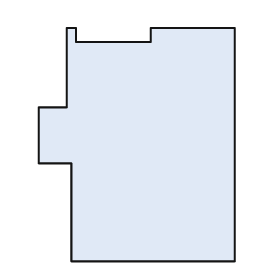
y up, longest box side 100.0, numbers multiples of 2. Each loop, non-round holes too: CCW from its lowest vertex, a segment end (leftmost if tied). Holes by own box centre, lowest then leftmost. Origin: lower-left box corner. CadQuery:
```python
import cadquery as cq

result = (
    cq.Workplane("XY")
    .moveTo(14.0, 0.0)
    .lineTo(84.0, 0.0)
    .lineTo(84.0, 100.0)
    .lineTo(48.0, 100.0)
    .lineTo(48.0, 94.0)
    .lineTo(16.0, 94.0)
    .lineTo(16.0, 100.0)
    .lineTo(12.0, 100.0)
    .lineTo(12.0, 66.0)
    .lineTo(0.0, 66.0)
    .lineTo(0.0, 42.0)
    .lineTo(14.0, 42.0)
    .close()
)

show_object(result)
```